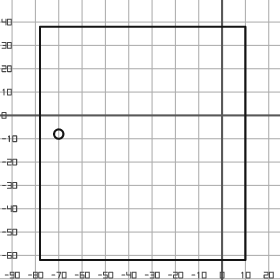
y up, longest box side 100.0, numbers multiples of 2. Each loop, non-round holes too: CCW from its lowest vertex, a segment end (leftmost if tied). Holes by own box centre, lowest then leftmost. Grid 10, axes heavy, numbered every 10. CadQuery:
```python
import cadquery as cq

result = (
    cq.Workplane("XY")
    .moveTo(-78.0, -62.0)
    .lineTo(10.0, -62.0)
    .lineTo(10.0, 38.0)
    .lineTo(-78.0, 38.0)
    .close()
    .moveTo(-70.0, -8.0)
    .circle(2.0)
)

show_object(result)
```